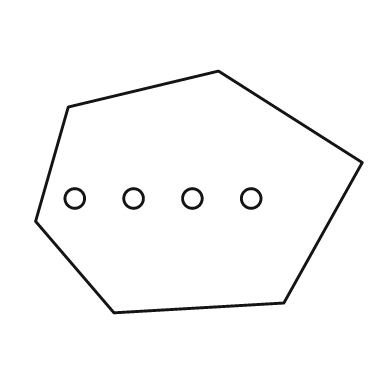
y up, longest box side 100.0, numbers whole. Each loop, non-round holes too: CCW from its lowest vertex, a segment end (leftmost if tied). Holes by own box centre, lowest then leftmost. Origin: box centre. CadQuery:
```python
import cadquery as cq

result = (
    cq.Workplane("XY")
    .moveTo(-26.0, -37.0)
    .lineTo(26.0, -34.0)
    .lineTo(50.0, 9.0)
    .lineTo(6.0, 37.0)
    .lineTo(-40.0, 26.0)
    .lineTo(-50.0, -9.0)
    .close()
    .moveTo(-38.0, -2.0)
    .circle(3.0)
    .moveTo(-20.0, -2.0)
    .circle(3.0)
    .moveTo(-2.0, -2.0)
    .circle(3.0)
    .moveTo(16.0, -2.0)
    .circle(3.0)
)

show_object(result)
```